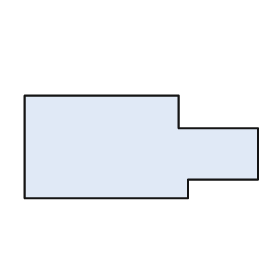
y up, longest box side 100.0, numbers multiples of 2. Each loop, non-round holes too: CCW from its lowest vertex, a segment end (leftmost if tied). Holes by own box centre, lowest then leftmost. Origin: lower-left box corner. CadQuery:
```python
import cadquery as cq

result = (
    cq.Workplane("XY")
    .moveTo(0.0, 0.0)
    .lineTo(70.0, 0.0)
    .lineTo(70.0, 8.0)
    .lineTo(100.0, 8.0)
    .lineTo(100.0, 30.0)
    .lineTo(66.0, 30.0)
    .lineTo(66.0, 44.0)
    .lineTo(0.0, 44.0)
    .close()
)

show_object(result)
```